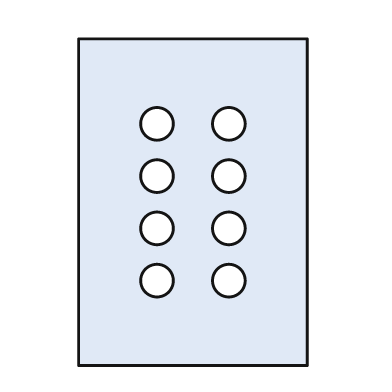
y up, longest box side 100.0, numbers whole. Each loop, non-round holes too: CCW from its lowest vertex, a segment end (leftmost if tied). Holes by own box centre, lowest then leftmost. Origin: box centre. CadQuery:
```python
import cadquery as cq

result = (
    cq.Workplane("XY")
    .moveTo(-35.0, -50.0)
    .lineTo(35.0, -50.0)
    .lineTo(35.0, 50.0)
    .lineTo(-35.0, 50.0)
    .close()
    .moveTo(-11.0, -24.0)
    .circle(5.0)
    .moveTo(11.0, -24.0)
    .circle(5.0)
    .moveTo(-11.0, -8.0)
    .circle(5.0)
    .moveTo(11.0, -8.0)
    .circle(5.0)
    .moveTo(-11.0, 8.0)
    .circle(5.0)
    .moveTo(11.0, 8.0)
    .circle(5.0)
    .moveTo(-11.0, 24.0)
    .circle(5.0)
    .moveTo(11.0, 24.0)
    .circle(5.0)
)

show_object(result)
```